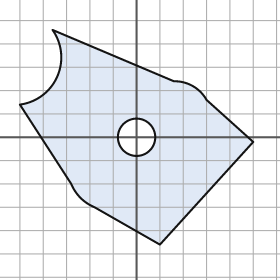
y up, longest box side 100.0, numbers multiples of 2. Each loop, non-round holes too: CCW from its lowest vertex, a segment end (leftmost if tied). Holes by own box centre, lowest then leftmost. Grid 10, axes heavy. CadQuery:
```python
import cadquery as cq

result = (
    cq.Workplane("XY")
    .moveTo(10.0, -46.0)
    .lineTo(50.0, -2.0)
    .lineTo(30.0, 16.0)
    .threePointArc((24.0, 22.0), (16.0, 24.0))
    .lineTo(-36.0, 46.0)
    .threePointArc((-34.0, 26.0), (-50.0, 14.0))
    .lineTo(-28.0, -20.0)
    .threePointArc((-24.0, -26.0), (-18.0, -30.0))
    .close()
    .moveTo(0.0, 0.0)
    .circle(8.0)
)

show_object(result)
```